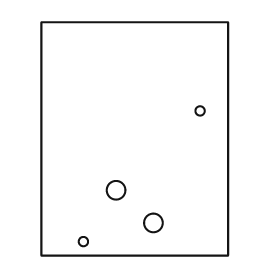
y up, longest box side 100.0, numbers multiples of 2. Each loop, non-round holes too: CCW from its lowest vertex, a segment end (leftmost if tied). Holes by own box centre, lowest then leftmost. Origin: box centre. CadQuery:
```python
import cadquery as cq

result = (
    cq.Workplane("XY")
    .moveTo(-40.0, -50.0)
    .lineTo(40.0, -50.0)
    .lineTo(40.0, 50.0)
    .lineTo(-40.0, 50.0)
    .close()
    .moveTo(-22.0, -44.0)
    .circle(2.0)
    .moveTo(8.0, -36.0)
    .circle(4.0)
    .moveTo(-8.0, -22.0)
    .circle(4.0)
    .moveTo(28.0, 12.0)
    .circle(2.0)
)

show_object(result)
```